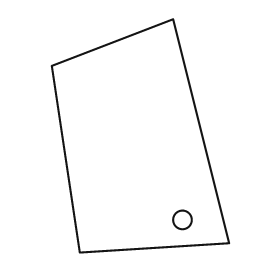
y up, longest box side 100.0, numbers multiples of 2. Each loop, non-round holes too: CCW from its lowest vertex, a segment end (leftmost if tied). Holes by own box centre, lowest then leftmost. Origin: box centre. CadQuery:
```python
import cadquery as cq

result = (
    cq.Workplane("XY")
    .moveTo(-26.0, -50.0)
    .lineTo(38.0, -46.0)
    .lineTo(14.0, 50.0)
    .lineTo(-38.0, 30.0)
    .close()
    .moveTo(18.0, -36.0)
    .circle(4.0)
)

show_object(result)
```